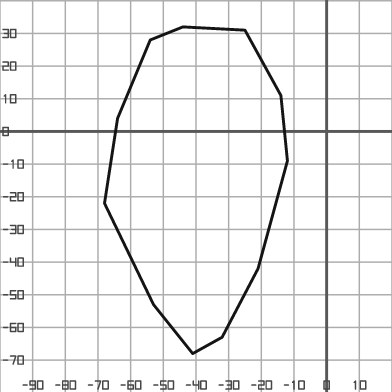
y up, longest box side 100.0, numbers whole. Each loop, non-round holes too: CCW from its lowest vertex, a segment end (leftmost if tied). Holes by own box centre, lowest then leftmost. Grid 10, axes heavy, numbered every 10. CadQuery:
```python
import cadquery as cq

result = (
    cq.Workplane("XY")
    .moveTo(-41.0, -68.0)
    .lineTo(-32.0, -63.0)
    .lineTo(-21.0, -42.0)
    .lineTo(-12.0, -9.0)
    .lineTo(-14.0, 11.0)
    .lineTo(-25.0, 31.0)
    .lineTo(-44.0, 32.0)
    .lineTo(-54.0, 28.0)
    .lineTo(-64.0, 4.0)
    .lineTo(-68.0, -22.0)
    .lineTo(-53.0, -53.0)
    .close()
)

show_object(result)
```